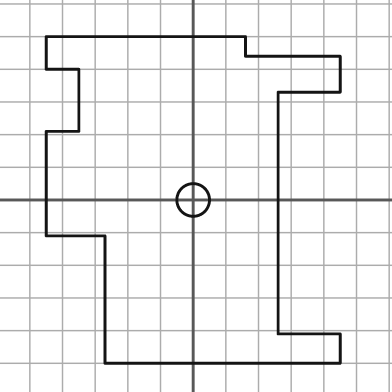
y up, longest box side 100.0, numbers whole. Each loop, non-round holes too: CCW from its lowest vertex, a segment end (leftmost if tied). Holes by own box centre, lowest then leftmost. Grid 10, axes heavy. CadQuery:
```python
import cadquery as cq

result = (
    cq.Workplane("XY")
    .moveTo(-27.0, -50.0)
    .lineTo(45.0, -50.0)
    .lineTo(45.0, -41.0)
    .lineTo(26.0, -41.0)
    .lineTo(26.0, 33.0)
    .lineTo(45.0, 33.0)
    .lineTo(45.0, 44.0)
    .lineTo(16.0, 44.0)
    .lineTo(16.0, 50.0)
    .lineTo(-45.0, 50.0)
    .lineTo(-45.0, 40.0)
    .lineTo(-35.0, 40.0)
    .lineTo(-35.0, 21.0)
    .lineTo(-45.0, 21.0)
    .lineTo(-45.0, -11.0)
    .lineTo(-27.0, -11.0)
    .close()
    .moveTo(0.0, 0.0)
    .circle(5.0)
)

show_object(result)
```